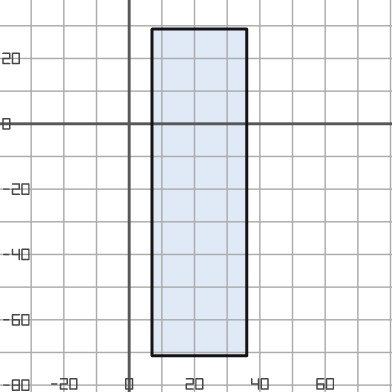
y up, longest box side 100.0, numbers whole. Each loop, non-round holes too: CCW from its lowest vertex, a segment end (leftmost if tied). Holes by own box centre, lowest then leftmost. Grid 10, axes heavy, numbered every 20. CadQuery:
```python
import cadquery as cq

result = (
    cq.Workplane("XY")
    .moveTo(7.0, -71.0)
    .lineTo(36.0, -71.0)
    .lineTo(36.0, 29.0)
    .lineTo(7.0, 29.0)
    .close()
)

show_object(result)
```